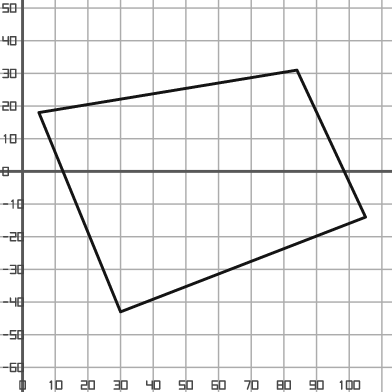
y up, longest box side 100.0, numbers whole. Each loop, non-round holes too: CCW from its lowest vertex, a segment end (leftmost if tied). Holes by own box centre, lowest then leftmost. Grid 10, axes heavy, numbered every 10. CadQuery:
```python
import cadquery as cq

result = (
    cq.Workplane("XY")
    .moveTo(30.0, -43.0)
    .lineTo(105.0, -14.0)
    .lineTo(84.0, 31.0)
    .lineTo(5.0, 18.0)
    .close()
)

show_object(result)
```